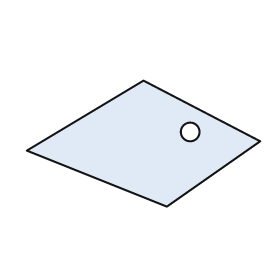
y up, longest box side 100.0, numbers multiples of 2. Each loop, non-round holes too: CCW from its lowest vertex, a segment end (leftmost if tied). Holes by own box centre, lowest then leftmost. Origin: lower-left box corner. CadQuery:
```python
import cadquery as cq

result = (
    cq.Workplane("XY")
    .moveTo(60.0, 0.0)
    .lineTo(100.0, 28.0)
    .lineTo(50.0, 54.0)
    .lineTo(0.0, 24.0)
    .close()
    .moveTo(70.0, 32.0)
    .circle(4.0)
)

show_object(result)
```